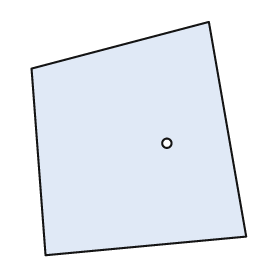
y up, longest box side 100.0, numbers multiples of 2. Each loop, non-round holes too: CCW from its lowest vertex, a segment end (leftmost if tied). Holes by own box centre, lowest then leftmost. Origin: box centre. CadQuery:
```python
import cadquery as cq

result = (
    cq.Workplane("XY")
    .moveTo(-40.0, -50.0)
    .lineTo(46.0, -42.0)
    .lineTo(30.0, 50.0)
    .lineTo(-46.0, 30.0)
    .close()
    .moveTo(12.0, -2.0)
    .circle(2.0)
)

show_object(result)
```